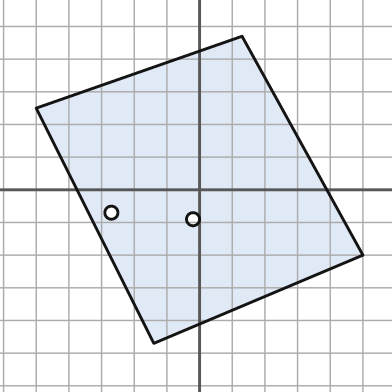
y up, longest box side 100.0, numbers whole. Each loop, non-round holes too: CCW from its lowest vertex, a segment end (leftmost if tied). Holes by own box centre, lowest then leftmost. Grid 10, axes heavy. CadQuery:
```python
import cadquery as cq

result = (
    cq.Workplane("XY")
    .moveTo(-14.0, -47.0)
    .lineTo(50.0, -20.0)
    .lineTo(13.0, 47.0)
    .lineTo(-50.0, 25.0)
    .close()
    .moveTo(-2.0, -9.0)
    .circle(2.0)
    .moveTo(-27.0, -7.0)
    .circle(2.0)
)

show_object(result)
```